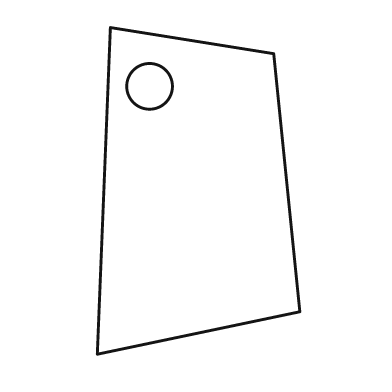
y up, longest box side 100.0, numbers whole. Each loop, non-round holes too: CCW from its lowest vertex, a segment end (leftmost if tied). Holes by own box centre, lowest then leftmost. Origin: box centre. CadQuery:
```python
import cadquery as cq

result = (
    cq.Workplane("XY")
    .moveTo(-31.0, -50.0)
    .lineTo(31.0, -37.0)
    .lineTo(23.0, 42.0)
    .lineTo(-27.0, 50.0)
    .close()
    .moveTo(-15.0, 32.0)
    .circle(7.0)
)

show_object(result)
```